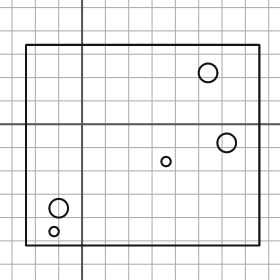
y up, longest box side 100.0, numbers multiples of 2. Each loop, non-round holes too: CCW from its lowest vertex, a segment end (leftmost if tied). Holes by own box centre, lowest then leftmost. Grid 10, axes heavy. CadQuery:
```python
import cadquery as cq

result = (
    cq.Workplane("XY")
    .moveTo(-24.0, -52.0)
    .lineTo(76.0, -52.0)
    .lineTo(76.0, 34.0)
    .lineTo(-24.0, 34.0)
    .close()
    .moveTo(-12.0, -46.0)
    .circle(2.0)
    .moveTo(-10.0, -36.0)
    .circle(4.0)
    .moveTo(36.0, -16.0)
    .circle(2.0)
    .moveTo(62.0, -8.0)
    .circle(4.0)
    .moveTo(54.0, 22.0)
    .circle(4.0)
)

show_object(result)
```